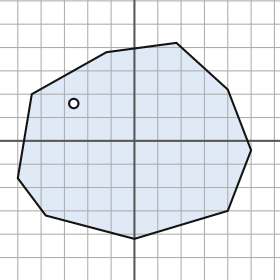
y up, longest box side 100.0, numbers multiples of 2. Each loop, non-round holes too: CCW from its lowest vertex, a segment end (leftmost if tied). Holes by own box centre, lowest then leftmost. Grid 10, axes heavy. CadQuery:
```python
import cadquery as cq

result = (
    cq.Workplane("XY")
    .moveTo(0.0, -42.0)
    .lineTo(40.0, -30.0)
    .lineTo(50.0, -4.0)
    .lineTo(40.0, 22.0)
    .lineTo(18.0, 42.0)
    .lineTo(-12.0, 38.0)
    .lineTo(-44.0, 20.0)
    .lineTo(-50.0, -16.0)
    .lineTo(-38.0, -32.0)
    .close()
    .moveTo(-26.0, 16.0)
    .circle(2.0)
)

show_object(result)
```